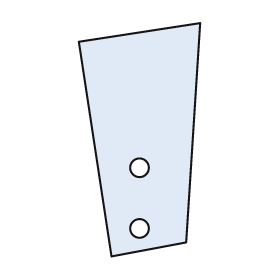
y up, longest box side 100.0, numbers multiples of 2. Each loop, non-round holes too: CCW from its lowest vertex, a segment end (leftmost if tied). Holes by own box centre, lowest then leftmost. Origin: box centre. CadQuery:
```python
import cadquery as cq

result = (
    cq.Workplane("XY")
    .moveTo(-12.0, -50.0)
    .lineTo(20.0, -44.0)
    .lineTo(26.0, 50.0)
    .lineTo(-26.0, 42.0)
    .close()
    .moveTo(0.0, -38.0)
    .circle(4.0)
    .moveTo(0.0, -12.0)
    .circle(4.0)
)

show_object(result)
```